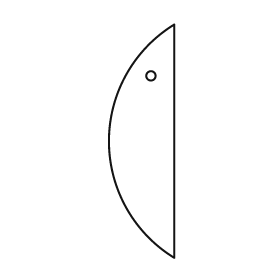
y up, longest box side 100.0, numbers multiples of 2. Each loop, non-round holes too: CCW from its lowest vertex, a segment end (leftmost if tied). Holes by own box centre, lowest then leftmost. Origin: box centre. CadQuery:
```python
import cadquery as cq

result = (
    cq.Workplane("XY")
    .moveTo(14.0, -50.0)
    .lineTo(14.0, 50.0)
    .threePointArc((-14.0, 0.0), (14.0, -50.0))
    .close()
    .moveTo(4.0, 28.0)
    .circle(2.0)
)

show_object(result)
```